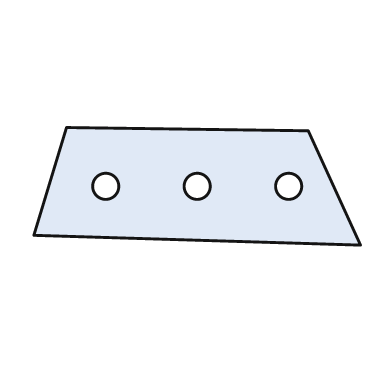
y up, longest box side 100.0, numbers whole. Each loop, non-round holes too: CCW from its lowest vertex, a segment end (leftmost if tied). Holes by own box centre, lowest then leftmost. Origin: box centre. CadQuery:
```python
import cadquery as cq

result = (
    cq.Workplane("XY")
    .moveTo(50.0, -18.0)
    .lineTo(34.0, 17.0)
    .lineTo(-40.0, 18.0)
    .lineTo(-50.0, -15.0)
    .close()
    .moveTo(-28.0, 0.0)
    .circle(4.0)
    .moveTo(0.0, 0.0)
    .circle(4.0)
    .moveTo(28.0, 0.0)
    .circle(4.0)
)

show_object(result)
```